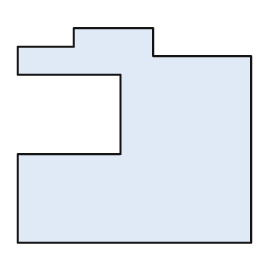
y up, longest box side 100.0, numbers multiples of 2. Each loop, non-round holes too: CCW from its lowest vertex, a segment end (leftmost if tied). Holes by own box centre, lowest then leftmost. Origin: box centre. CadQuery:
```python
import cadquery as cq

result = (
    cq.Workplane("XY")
    .moveTo(-50.0, -46.0)
    .lineTo(50.0, -46.0)
    .lineTo(50.0, 34.0)
    .lineTo(8.0, 34.0)
    .lineTo(8.0, 46.0)
    .lineTo(-26.0, 46.0)
    .lineTo(-26.0, 38.0)
    .lineTo(-50.0, 38.0)
    .lineTo(-50.0, 26.0)
    .lineTo(-6.0, 26.0)
    .lineTo(-6.0, -8.0)
    .lineTo(-50.0, -8.0)
    .close()
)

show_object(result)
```